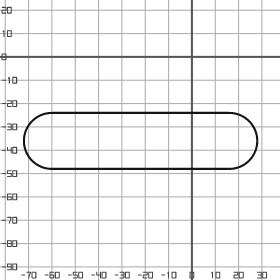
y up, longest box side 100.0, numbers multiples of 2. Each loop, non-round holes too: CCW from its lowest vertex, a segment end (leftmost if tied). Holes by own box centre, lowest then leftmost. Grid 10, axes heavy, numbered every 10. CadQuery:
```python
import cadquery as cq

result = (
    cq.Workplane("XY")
    .moveTo(-60.0, -48.0)
    .lineTo(16.0, -48.0)
    .threePointArc((28.0, -36.0), (16.0, -24.0))
    .lineTo(-60.0, -24.0)
    .threePointArc((-72.0, -36.0), (-60.0, -48.0))
    .close()
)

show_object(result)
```